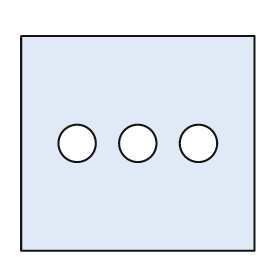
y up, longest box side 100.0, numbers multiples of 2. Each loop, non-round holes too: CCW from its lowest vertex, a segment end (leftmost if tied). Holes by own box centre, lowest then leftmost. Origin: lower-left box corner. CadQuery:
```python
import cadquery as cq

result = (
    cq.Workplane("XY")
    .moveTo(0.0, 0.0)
    .lineTo(100.0, 0.0)
    .lineTo(100.0, 92.0)
    .lineTo(0.0, 92.0)
    .close()
    .moveTo(24.0, 46.0)
    .circle(8.0)
    .moveTo(50.0, 46.0)
    .circle(8.0)
    .moveTo(76.0, 46.0)
    .circle(8.0)
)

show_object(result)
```